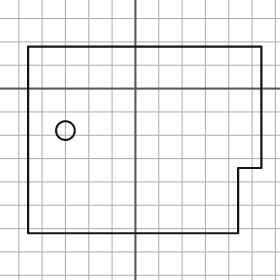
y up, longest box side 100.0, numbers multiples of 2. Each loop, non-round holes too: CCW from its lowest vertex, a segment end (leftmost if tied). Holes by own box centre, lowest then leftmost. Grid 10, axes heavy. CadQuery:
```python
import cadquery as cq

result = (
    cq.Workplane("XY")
    .moveTo(-46.0, -62.0)
    .lineTo(44.0, -62.0)
    .lineTo(44.0, -34.0)
    .lineTo(54.0, -34.0)
    .lineTo(54.0, 18.0)
    .lineTo(-46.0, 18.0)
    .close()
    .moveTo(-30.0, -18.0)
    .circle(4.0)
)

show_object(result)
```